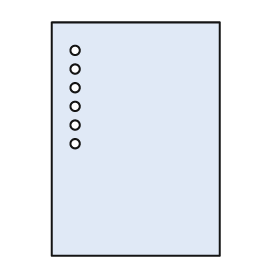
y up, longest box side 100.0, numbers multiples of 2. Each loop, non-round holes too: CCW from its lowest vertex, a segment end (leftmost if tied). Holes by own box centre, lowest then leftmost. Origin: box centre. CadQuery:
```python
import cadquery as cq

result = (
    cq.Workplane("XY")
    .moveTo(-36.0, -50.0)
    .lineTo(36.0, -50.0)
    .lineTo(36.0, 50.0)
    .lineTo(-36.0, 50.0)
    .close()
    .moveTo(-26.0, -2.0)
    .circle(2.0)
    .moveTo(-26.0, 6.0)
    .circle(2.0)
    .moveTo(-26.0, 14.0)
    .circle(2.0)
    .moveTo(-26.0, 22.0)
    .circle(2.0)
    .moveTo(-26.0, 30.0)
    .circle(2.0)
    .moveTo(-26.0, 38.0)
    .circle(2.0)
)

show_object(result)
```